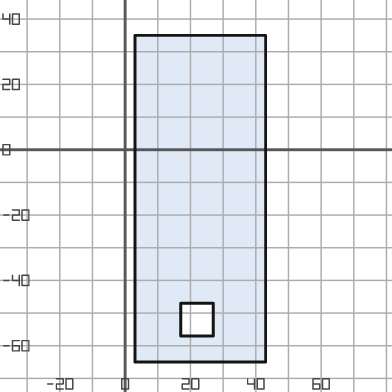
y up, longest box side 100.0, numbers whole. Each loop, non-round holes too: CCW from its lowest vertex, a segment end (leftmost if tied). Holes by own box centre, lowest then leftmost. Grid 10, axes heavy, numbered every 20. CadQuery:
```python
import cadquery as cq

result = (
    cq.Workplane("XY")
    .moveTo(3.0, -65.0)
    .lineTo(43.0, -65.0)
    .lineTo(43.0, 35.0)
    .lineTo(3.0, 35.0)
    .close()
    .moveTo(17.0, -57.0)
    .lineTo(27.0, -57.0)
    .lineTo(27.0, -47.0)
    .lineTo(17.0, -47.0)
    .close()
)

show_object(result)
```